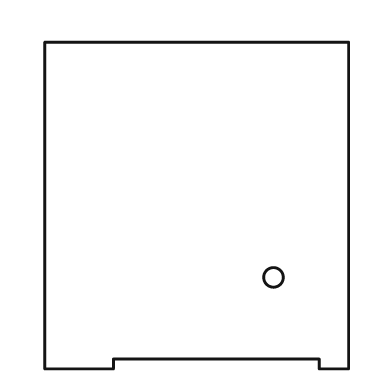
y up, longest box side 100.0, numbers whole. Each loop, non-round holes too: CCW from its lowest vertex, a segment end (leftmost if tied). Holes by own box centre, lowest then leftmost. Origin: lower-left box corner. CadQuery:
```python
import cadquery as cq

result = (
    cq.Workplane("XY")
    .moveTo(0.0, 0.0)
    .lineTo(21.0, 0.0)
    .lineTo(21.0, 3.0)
    .lineTo(84.0, 3.0)
    .lineTo(84.0, 0.0)
    .lineTo(93.0, 0.0)
    .lineTo(93.0, 100.0)
    .lineTo(0.0, 100.0)
    .close()
    .moveTo(70.0, 28.0)
    .circle(3.0)
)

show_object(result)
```